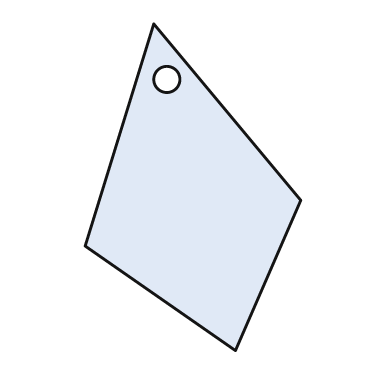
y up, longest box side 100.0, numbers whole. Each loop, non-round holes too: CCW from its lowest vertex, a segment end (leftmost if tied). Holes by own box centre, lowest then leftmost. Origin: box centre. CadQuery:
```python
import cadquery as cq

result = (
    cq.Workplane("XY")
    .moveTo(13.0, -50.0)
    .lineTo(33.0, -4.0)
    .lineTo(-12.0, 50.0)
    .lineTo(-33.0, -18.0)
    .close()
    .moveTo(-8.0, 33.0)
    .circle(4.0)
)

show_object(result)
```